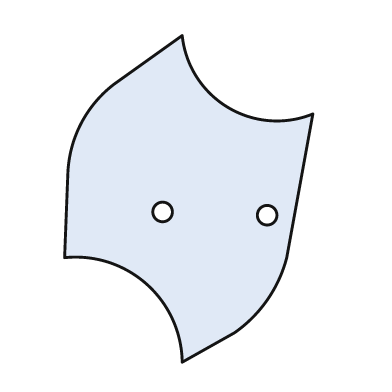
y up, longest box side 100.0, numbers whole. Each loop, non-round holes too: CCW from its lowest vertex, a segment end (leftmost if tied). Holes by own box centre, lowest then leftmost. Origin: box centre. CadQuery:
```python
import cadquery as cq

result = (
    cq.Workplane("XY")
    .moveTo(-2.0, -50.0)
    .lineTo(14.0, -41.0)
    .threePointArc((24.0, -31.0), (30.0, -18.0))
    .lineTo(38.0, 26.0)
    .threePointArc((12.0, 28.0), (-2.0, 50.0))
    .lineTo(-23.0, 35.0)
    .threePointArc((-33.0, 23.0), (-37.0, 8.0))
    .lineTo(-38.0, -18.0)
    .threePointArc((-13.0, -26.0), (-2.0, -50.0))
    .close()
    .moveTo(24.0, -5.0)
    .circle(3.0)
    .moveTo(-8.0, -4.0)
    .circle(3.0)
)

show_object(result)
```